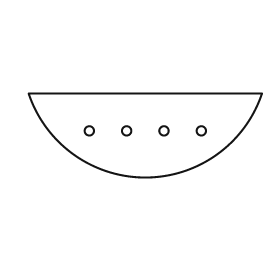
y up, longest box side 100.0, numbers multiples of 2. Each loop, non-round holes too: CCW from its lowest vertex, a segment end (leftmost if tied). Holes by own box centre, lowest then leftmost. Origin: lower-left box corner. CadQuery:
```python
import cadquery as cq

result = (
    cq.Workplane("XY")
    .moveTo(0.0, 36.0)
    .threePointArc((50.0, 0.0), (100.0, 36.0))
    .close()
    .moveTo(26.0, 20.0)
    .circle(2.0)
    .moveTo(42.0, 20.0)
    .circle(2.0)
    .moveTo(58.0, 20.0)
    .circle(2.0)
    .moveTo(74.0, 20.0)
    .circle(2.0)
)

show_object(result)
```